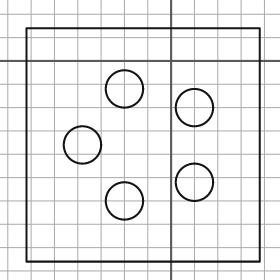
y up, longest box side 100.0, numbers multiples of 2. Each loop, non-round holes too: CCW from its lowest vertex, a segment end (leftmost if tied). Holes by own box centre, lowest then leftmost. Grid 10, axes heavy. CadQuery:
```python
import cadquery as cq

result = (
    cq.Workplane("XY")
    .moveTo(-62.0, -86.0)
    .lineTo(38.0, -86.0)
    .lineTo(38.0, 14.0)
    .lineTo(-62.0, 14.0)
    .close()
    .moveTo(-20.0, -60.0)
    .circle(8.0)
    .moveTo(10.0, -52.0)
    .circle(8.0)
    .moveTo(-38.0, -36.0)
    .circle(8.0)
    .moveTo(10.0, -20.0)
    .circle(8.0)
    .moveTo(-20.0, -12.0)
    .circle(8.0)
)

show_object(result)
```